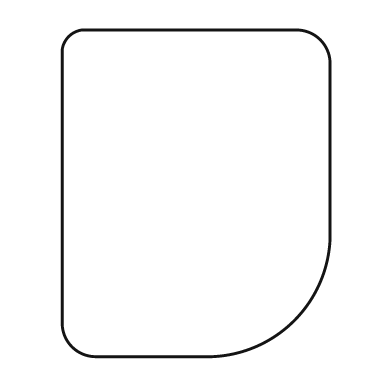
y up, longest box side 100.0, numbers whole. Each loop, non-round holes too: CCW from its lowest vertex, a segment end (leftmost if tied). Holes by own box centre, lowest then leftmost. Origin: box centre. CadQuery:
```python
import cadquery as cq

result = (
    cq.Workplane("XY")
    .moveTo(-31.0, -50.0)
    .lineTo(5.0, -50.0)
    .threePointArc((30.0, -39.0), (41.0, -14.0))
    .lineTo(41.0, 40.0)
    .threePointArc((38.0, 47.0), (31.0, 50.0))
    .lineTo(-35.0, 50.0)
    .threePointArc((-39.0, 48.0), (-41.0, 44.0))
    .lineTo(-41.0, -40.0)
    .threePointArc((-38.0, -47.0), (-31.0, -50.0))
    .close()
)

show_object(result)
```